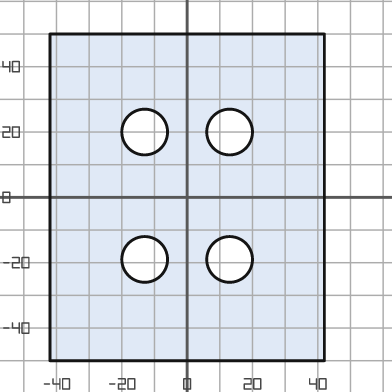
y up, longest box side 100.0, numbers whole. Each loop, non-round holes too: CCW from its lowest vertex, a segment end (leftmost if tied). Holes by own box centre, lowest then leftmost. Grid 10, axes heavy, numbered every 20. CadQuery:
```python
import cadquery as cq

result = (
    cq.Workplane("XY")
    .moveTo(-42.0, -50.0)
    .lineTo(42.0, -50.0)
    .lineTo(42.0, 50.0)
    .lineTo(-42.0, 50.0)
    .close()
    .moveTo(-13.0, -19.0)
    .circle(7.0)
    .moveTo(13.0, -19.0)
    .circle(7.0)
    .moveTo(-13.0, 20.0)
    .circle(7.0)
    .moveTo(13.0, 20.0)
    .circle(7.0)
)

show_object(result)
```